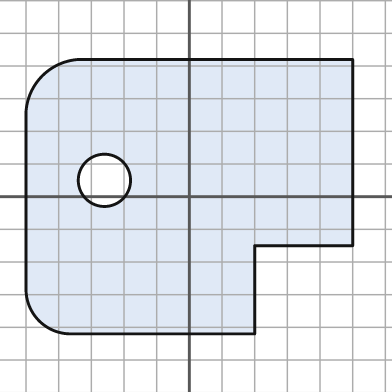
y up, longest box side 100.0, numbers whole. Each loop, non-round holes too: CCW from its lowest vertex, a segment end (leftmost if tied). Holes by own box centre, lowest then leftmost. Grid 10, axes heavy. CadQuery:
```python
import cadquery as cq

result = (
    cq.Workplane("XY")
    .moveTo(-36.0, -42.0)
    .lineTo(20.0, -42.0)
    .lineTo(20.0, -15.0)
    .lineTo(50.0, -15.0)
    .lineTo(50.0, 42.0)
    .lineTo(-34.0, 42.0)
    .threePointArc((-45.0, 37.0), (-50.0, 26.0))
    .lineTo(-50.0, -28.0)
    .threePointArc((-46.0, -38.0), (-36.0, -42.0))
    .close()
    .moveTo(-26.0, 5.0)
    .circle(8.0)
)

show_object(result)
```